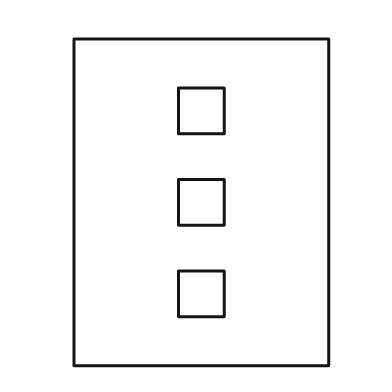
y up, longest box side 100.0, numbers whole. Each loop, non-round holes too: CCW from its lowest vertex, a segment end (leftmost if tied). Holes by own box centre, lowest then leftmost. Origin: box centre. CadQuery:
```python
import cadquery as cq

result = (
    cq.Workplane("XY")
    .moveTo(-39.0, -50.0)
    .lineTo(39.0, -50.0)
    .lineTo(39.0, 50.0)
    .lineTo(-39.0, 50.0)
    .close()
    .moveTo(-7.0, -35.0)
    .lineTo(7.0, -35.0)
    .lineTo(7.0, -21.0)
    .lineTo(-7.0, -21.0)
    .close()
    .moveTo(-7.0, -7.0)
    .lineTo(7.0, -7.0)
    .lineTo(7.0, 7.0)
    .lineTo(-7.0, 7.0)
    .close()
    .moveTo(-7.0, 21.0)
    .lineTo(7.0, 21.0)
    .lineTo(7.0, 35.0)
    .lineTo(-7.0, 35.0)
    .close()
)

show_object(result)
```